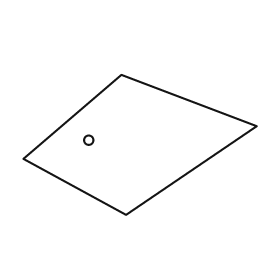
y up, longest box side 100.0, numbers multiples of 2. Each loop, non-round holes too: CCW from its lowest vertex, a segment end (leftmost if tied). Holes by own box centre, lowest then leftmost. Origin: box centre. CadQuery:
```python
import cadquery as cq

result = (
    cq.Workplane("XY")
    .moveTo(-6.0, -30.0)
    .lineTo(50.0, 8.0)
    .lineTo(-8.0, 30.0)
    .lineTo(-50.0, -6.0)
    .close()
    .moveTo(-22.0, 2.0)
    .circle(2.0)
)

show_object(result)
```